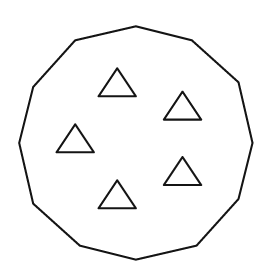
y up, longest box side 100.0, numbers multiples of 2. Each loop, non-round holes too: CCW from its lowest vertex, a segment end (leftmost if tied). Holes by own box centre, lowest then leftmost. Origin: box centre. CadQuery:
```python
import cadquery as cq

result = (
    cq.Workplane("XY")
    .moveTo(0.0, -50.0)
    .lineTo(26.0, -44.0)
    .lineTo(44.0, -24.0)
    .lineTo(50.0, 0.0)
    .lineTo(44.0, 26.0)
    .lineTo(24.0, 44.0)
    .lineTo(0.0, 50.0)
    .lineTo(-26.0, 44.0)
    .lineTo(-44.0, 24.0)
    .lineTo(-50.0, 0.0)
    .lineTo(-44.0, -26.0)
    .lineTo(-24.0, -44.0)
    .close()
    .moveTo(-16.0, -28.0)
    .lineTo(0.0, -28.0)
    .lineTo(-8.0, -16.0)
    .close()
    .moveTo(12.0, -18.0)
    .lineTo(28.0, -18.0)
    .lineTo(20.0, -6.0)
    .close()
    .moveTo(-34.0, -4.0)
    .lineTo(-18.0, -4.0)
    .lineTo(-26.0, 8.0)
    .close()
    .moveTo(12.0, 10.0)
    .lineTo(28.0, 10.0)
    .lineTo(20.0, 22.0)
    .close()
    .moveTo(-16.0, 20.0)
    .lineTo(0.0, 20.0)
    .lineTo(-8.0, 32.0)
    .close()
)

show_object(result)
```